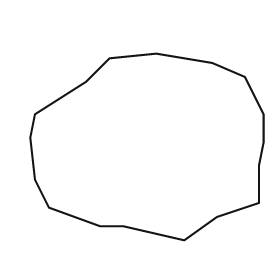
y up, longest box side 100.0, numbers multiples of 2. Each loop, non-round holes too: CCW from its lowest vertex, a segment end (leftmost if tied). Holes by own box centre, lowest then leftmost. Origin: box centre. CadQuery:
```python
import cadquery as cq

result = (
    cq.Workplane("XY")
    .moveTo(16.0, -40.0)
    .lineTo(30.0, -30.0)
    .lineTo(48.0, -24.0)
    .lineTo(48.0, -8.0)
    .lineTo(50.0, 2.0)
    .lineTo(50.0, 14.0)
    .lineTo(42.0, 30.0)
    .lineTo(28.0, 36.0)
    .lineTo(4.0, 40.0)
    .lineTo(-16.0, 38.0)
    .lineTo(-26.0, 28.0)
    .lineTo(-48.0, 14.0)
    .lineTo(-50.0, 4.0)
    .lineTo(-48.0, -14.0)
    .lineTo(-42.0, -26.0)
    .lineTo(-20.0, -34.0)
    .lineTo(-10.0, -34.0)
    .close()
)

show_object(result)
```